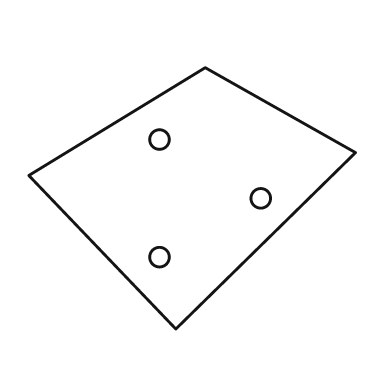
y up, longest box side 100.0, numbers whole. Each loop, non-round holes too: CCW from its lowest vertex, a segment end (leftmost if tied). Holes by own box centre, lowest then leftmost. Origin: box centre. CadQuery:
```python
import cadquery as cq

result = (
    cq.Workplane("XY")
    .moveTo(-5.0, -40.0)
    .lineTo(50.0, 14.0)
    .lineTo(4.0, 40.0)
    .lineTo(-50.0, 7.0)
    .close()
    .moveTo(-10.0, -18.0)
    .circle(3.0)
    .moveTo(21.0, 0.0)
    .circle(3.0)
    .moveTo(-10.0, 18.0)
    .circle(3.0)
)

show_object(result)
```